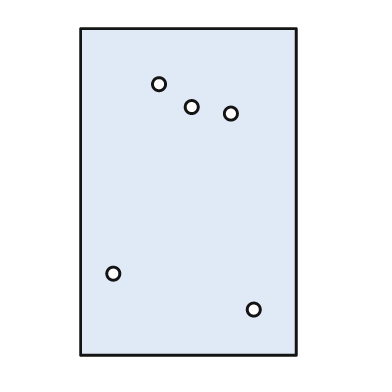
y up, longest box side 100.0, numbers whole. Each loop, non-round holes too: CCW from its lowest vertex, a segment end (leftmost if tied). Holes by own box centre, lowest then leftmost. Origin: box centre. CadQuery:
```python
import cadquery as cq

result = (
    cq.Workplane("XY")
    .moveTo(-33.0, -50.0)
    .lineTo(33.0, -50.0)
    .lineTo(33.0, 50.0)
    .lineTo(-33.0, 50.0)
    .close()
    .moveTo(20.0, -36.0)
    .circle(2.0)
    .moveTo(-23.0, -25.0)
    .circle(2.0)
    .moveTo(13.0, 24.0)
    .circle(2.0)
    .moveTo(1.0, 26.0)
    .circle(2.0)
    .moveTo(-9.0, 33.0)
    .circle(2.0)
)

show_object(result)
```